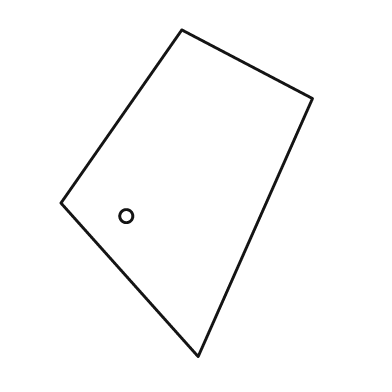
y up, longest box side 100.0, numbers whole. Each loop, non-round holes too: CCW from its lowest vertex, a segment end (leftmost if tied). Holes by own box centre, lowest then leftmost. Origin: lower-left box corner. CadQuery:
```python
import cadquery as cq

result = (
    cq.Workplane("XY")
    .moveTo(42.0, 0.0)
    .lineTo(77.0, 79.0)
    .lineTo(37.0, 100.0)
    .lineTo(0.0, 47.0)
    .close()
    .moveTo(20.0, 43.0)
    .circle(2.0)
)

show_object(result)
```